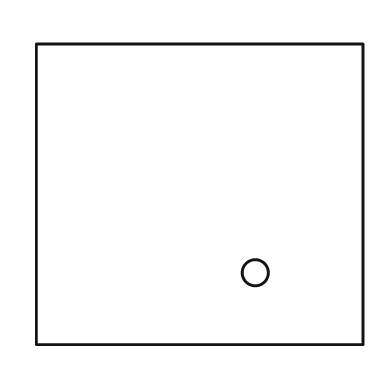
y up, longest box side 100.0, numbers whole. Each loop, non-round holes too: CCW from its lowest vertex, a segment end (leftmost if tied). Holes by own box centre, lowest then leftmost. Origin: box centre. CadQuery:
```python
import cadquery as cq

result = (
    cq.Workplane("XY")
    .moveTo(-50.0, -46.0)
    .lineTo(50.0, -46.0)
    .lineTo(50.0, 46.0)
    .lineTo(-50.0, 46.0)
    .close()
    .moveTo(17.0, -24.0)
    .circle(4.0)
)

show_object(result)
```